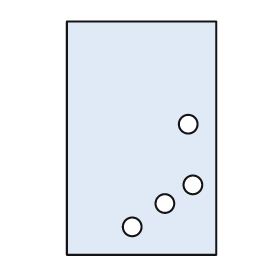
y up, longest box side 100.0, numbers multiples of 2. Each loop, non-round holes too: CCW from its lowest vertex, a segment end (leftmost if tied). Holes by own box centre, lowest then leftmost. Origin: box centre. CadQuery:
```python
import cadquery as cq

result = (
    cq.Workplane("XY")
    .moveTo(-32.0, -50.0)
    .lineTo(32.0, -50.0)
    .lineTo(32.0, 50.0)
    .lineTo(-32.0, 50.0)
    .close()
    .moveTo(-4.0, -38.0)
    .circle(4.0)
    .moveTo(10.0, -28.0)
    .circle(4.0)
    .moveTo(22.0, -20.0)
    .circle(4.0)
    .moveTo(20.0, 6.0)
    .circle(4.0)
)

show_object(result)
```